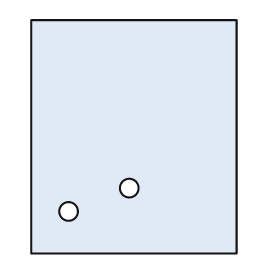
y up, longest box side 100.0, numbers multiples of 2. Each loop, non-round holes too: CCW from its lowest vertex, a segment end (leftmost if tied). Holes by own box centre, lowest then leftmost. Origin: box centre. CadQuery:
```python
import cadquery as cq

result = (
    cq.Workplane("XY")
    .moveTo(-44.0, -50.0)
    .lineTo(44.0, -50.0)
    .lineTo(44.0, 50.0)
    .lineTo(-44.0, 50.0)
    .close()
    .moveTo(-28.0, -32.0)
    .circle(4.0)
    .moveTo(-2.0, -22.0)
    .circle(4.0)
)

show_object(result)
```